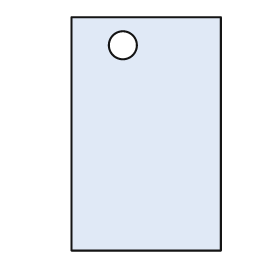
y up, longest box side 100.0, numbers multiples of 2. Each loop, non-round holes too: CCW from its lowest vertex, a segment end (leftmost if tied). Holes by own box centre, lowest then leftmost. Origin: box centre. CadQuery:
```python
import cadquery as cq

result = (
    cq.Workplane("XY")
    .moveTo(-32.0, -50.0)
    .lineTo(32.0, -50.0)
    .lineTo(32.0, 50.0)
    .lineTo(-32.0, 50.0)
    .close()
    .moveTo(-10.0, 38.0)
    .circle(6.0)
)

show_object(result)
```